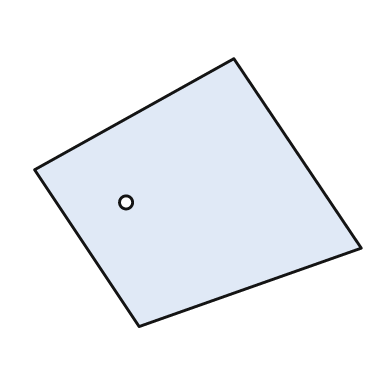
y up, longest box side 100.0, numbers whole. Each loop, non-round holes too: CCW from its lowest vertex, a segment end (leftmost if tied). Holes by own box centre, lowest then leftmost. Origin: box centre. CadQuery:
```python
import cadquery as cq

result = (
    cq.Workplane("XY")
    .moveTo(-18.0, -41.0)
    .lineTo(50.0, -17.0)
    .lineTo(11.0, 41.0)
    .lineTo(-50.0, 7.0)
    .close()
    .moveTo(-22.0, -3.0)
    .circle(2.0)
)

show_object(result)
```